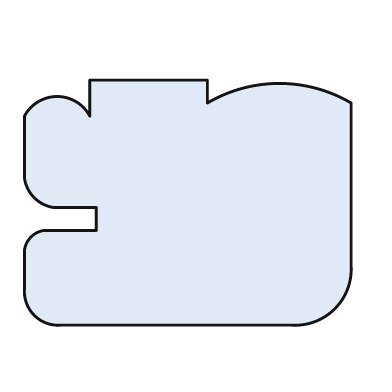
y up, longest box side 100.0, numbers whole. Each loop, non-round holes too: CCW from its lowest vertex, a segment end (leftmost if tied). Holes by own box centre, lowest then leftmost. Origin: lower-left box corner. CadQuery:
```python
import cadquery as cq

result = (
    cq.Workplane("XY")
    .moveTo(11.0, 0.0)
    .lineTo(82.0, 0.0)
    .threePointArc((95.0, 5.0), (100.0, 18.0))
    .lineTo(100.0, 68.0)
    .threePointArc((78.0, 74.0), (56.0, 68.0))
    .lineTo(56.0, 75.0)
    .lineTo(20.0, 75.0)
    .lineTo(20.0, 64.0)
    .threePointArc((10.0, 70.0), (0.0, 64.0))
    .lineTo(0.0, 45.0)
    .threePointArc((3.0, 39.0), (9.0, 36.0))
    .lineTo(22.0, 36.0)
    .lineTo(22.0, 29.0)
    .lineTo(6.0, 29.0)
    .threePointArc((2.0, 27.0), (0.0, 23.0))
    .lineTo(0.0, 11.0)
    .threePointArc((3.0, 3.0), (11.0, 0.0))
    .close()
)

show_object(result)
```